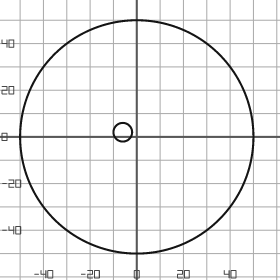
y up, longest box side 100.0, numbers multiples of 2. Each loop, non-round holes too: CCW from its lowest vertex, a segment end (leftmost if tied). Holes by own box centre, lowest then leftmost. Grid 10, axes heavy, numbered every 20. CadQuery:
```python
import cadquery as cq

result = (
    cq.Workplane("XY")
    .moveTo(0.0, 0.0)
    .circle(50.0)
    .moveTo(-6.0, 2.0)
    .circle(4.0)
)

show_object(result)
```